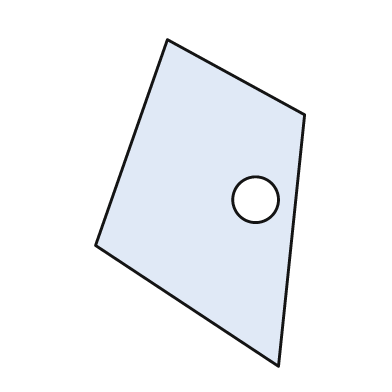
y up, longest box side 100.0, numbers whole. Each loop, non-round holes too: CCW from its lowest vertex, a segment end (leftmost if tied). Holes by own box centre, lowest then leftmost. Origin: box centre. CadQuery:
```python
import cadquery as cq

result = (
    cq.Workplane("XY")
    .moveTo(24.0, -50.0)
    .lineTo(32.0, 27.0)
    .lineTo(-10.0, 50.0)
    .lineTo(-32.0, -13.0)
    .close()
    .moveTo(17.0, 1.0)
    .circle(7.0)
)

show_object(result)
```